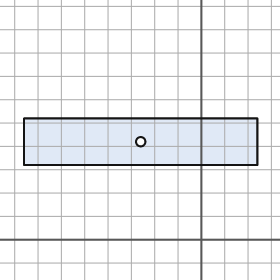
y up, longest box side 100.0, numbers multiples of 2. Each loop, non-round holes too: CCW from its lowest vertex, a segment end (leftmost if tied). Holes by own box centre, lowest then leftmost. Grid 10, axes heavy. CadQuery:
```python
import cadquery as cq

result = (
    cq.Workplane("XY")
    .moveTo(-76.0, 32.0)
    .lineTo(24.0, 32.0)
    .lineTo(24.0, 52.0)
    .lineTo(-76.0, 52.0)
    .close()
    .moveTo(-26.0, 42.0)
    .circle(2.0)
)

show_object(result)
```